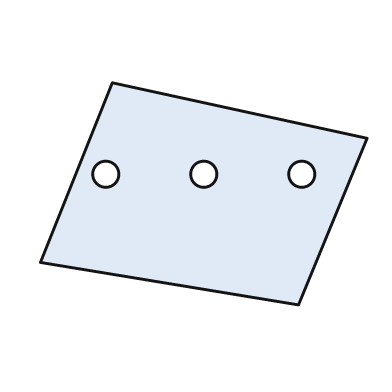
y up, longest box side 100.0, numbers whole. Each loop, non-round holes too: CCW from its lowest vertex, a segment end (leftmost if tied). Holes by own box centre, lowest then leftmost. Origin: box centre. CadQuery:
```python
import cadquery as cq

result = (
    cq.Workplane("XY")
    .moveTo(29.0, -34.0)
    .lineTo(50.0, 17.0)
    .lineTo(-28.0, 34.0)
    .lineTo(-50.0, -21.0)
    .close()
    .moveTo(-30.0, 6.0)
    .circle(4.0)
    .moveTo(0.0, 6.0)
    .circle(4.0)
    .moveTo(30.0, 6.0)
    .circle(4.0)
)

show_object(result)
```